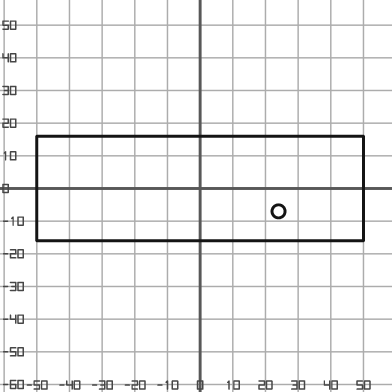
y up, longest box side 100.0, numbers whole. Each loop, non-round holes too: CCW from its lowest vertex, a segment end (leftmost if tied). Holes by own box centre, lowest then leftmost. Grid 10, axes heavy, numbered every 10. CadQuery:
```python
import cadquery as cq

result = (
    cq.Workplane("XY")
    .moveTo(-50.0, -16.0)
    .lineTo(50.0, -16.0)
    .lineTo(50.0, 16.0)
    .lineTo(-50.0, 16.0)
    .close()
    .moveTo(24.0, -7.0)
    .circle(2.0)
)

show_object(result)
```